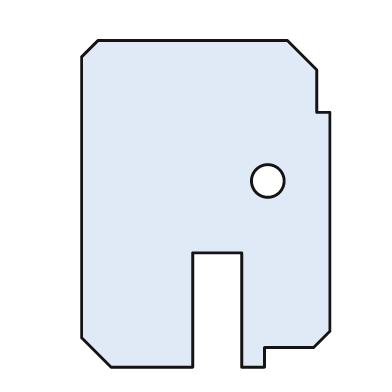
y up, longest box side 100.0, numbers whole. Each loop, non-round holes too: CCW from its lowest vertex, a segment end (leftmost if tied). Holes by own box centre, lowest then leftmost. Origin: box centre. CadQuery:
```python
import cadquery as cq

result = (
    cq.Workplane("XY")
    .moveTo(-29.0, -50.0)
    .lineTo(-4.0, -50.0)
    .lineTo(-4.0, -15.0)
    .lineTo(11.0, -15.0)
    .lineTo(11.0, -50.0)
    .lineTo(18.0, -50.0)
    .lineTo(18.0, -44.0)
    .lineTo(33.0, -44.0)
    .lineTo(38.0, -39.0)
    .lineTo(38.0, 28.0)
    .lineTo(34.0, 28.0)
    .lineTo(34.0, 41.0)
    .lineTo(25.0, 50.0)
    .lineTo(-33.0, 50.0)
    .lineTo(-38.0, 45.0)
    .lineTo(-38.0, -41.0)
    .close()
    .moveTo(19.0, 7.0)
    .circle(5.0)
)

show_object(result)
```